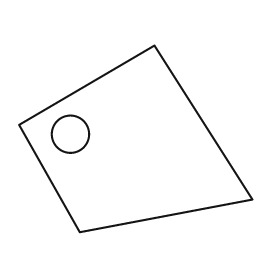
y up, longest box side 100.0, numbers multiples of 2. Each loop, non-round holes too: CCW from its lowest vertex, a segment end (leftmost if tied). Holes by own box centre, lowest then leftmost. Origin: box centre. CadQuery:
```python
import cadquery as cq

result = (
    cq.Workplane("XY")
    .moveTo(-24.0, -40.0)
    .lineTo(50.0, -26.0)
    .lineTo(8.0, 40.0)
    .lineTo(-50.0, 6.0)
    .close()
    .moveTo(-28.0, 2.0)
    .circle(8.0)
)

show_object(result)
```